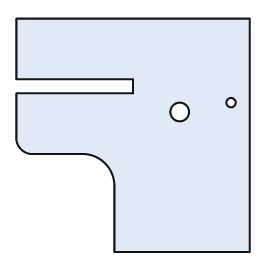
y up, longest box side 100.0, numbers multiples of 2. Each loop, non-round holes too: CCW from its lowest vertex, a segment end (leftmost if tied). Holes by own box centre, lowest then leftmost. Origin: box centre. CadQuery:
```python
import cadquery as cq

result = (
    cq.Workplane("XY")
    .moveTo(-8.0, -50.0)
    .lineTo(50.0, -50.0)
    .lineTo(50.0, 50.0)
    .lineTo(-50.0, 50.0)
    .lineTo(-50.0, 24.0)
    .lineTo(0.0, 24.0)
    .lineTo(0.0, 18.0)
    .lineTo(-50.0, 18.0)
    .lineTo(-50.0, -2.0)
    .threePointArc((-48.0, -6.0), (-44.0, -8.0))
    .lineTo(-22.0, -8.0)
    .threePointArc((-12.0, -12.0), (-8.0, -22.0))
    .close()
    .moveTo(20.0, 10.0)
    .circle(4.0)
    .moveTo(42.0, 14.0)
    .circle(2.0)
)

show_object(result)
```